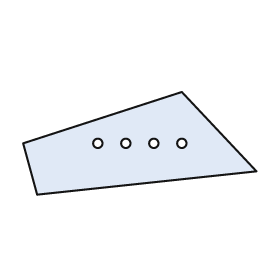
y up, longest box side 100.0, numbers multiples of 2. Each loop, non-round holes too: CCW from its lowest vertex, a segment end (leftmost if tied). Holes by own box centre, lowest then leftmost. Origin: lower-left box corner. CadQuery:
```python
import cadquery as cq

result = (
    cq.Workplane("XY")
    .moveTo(6.0, 0.0)
    .lineTo(100.0, 10.0)
    .lineTo(68.0, 44.0)
    .lineTo(0.0, 22.0)
    .close()
    .moveTo(32.0, 22.0)
    .circle(2.0)
    .moveTo(44.0, 22.0)
    .circle(2.0)
    .moveTo(56.0, 22.0)
    .circle(2.0)
    .moveTo(68.0, 22.0)
    .circle(2.0)
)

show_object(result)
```